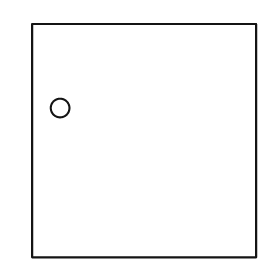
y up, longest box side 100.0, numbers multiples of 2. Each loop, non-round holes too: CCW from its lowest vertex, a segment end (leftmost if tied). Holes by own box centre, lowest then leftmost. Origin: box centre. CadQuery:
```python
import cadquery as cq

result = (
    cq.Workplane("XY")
    .moveTo(-48.0, -50.0)
    .lineTo(48.0, -50.0)
    .lineTo(48.0, 50.0)
    .lineTo(-48.0, 50.0)
    .close()
    .moveTo(-36.0, 14.0)
    .circle(4.0)
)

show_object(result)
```